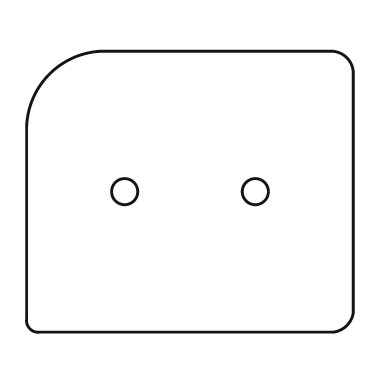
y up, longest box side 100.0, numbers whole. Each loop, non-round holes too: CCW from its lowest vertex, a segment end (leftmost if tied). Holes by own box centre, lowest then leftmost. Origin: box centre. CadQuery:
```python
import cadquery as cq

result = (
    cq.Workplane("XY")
    .moveTo(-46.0, -43.0)
    .lineTo(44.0, -43.0)
    .threePointArc((48.0, -41.0), (50.0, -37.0))
    .lineTo(50.0, 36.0)
    .threePointArc((48.0, 41.0), (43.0, 43.0))
    .lineTo(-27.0, 43.0)
    .threePointArc((-43.0, 36.0), (-50.0, 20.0))
    .lineTo(-50.0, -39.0)
    .threePointArc((-49.0, -42.0), (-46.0, -43.0))
    .close()
    .moveTo(-20.0, 0.0)
    .circle(4.0)
    .moveTo(20.0, 0.0)
    .circle(4.0)
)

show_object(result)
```